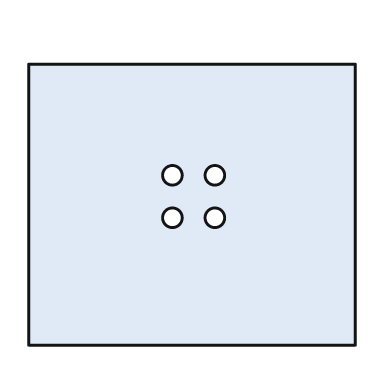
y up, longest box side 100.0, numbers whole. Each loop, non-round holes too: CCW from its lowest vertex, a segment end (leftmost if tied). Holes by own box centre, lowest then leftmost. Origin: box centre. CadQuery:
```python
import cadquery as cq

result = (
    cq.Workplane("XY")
    .moveTo(-50.0, -43.0)
    .lineTo(50.0, -43.0)
    .lineTo(50.0, 43.0)
    .lineTo(-50.0, 43.0)
    .close()
    .moveTo(-6.0, -4.0)
    .circle(3.0)
    .moveTo(7.0, -4.0)
    .circle(3.0)
    .moveTo(-6.0, 9.0)
    .circle(3.0)
    .moveTo(7.0, 9.0)
    .circle(3.0)
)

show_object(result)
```